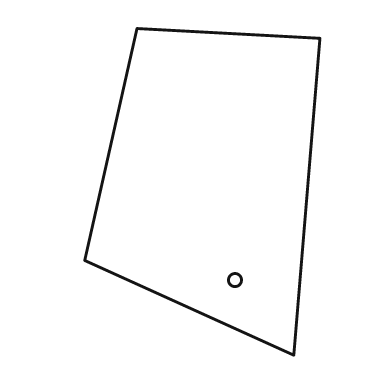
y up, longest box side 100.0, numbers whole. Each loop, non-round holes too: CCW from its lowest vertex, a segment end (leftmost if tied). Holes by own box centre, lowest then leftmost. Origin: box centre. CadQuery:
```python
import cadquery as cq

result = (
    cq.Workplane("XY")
    .moveTo(28.0, -50.0)
    .lineTo(36.0, 47.0)
    .lineTo(-20.0, 50.0)
    .lineTo(-36.0, -21.0)
    .close()
    .moveTo(10.0, -27.0)
    .circle(2.0)
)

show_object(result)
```